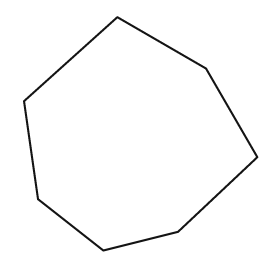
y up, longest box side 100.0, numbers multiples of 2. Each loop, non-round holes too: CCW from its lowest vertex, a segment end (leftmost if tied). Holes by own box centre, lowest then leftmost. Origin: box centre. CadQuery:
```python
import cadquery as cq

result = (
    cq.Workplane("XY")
    .moveTo(-16.0, -50.0)
    .lineTo(16.0, -42.0)
    .lineTo(50.0, -10.0)
    .lineTo(28.0, 28.0)
    .lineTo(-10.0, 50.0)
    .lineTo(-50.0, 14.0)
    .lineTo(-44.0, -28.0)
    .close()
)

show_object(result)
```